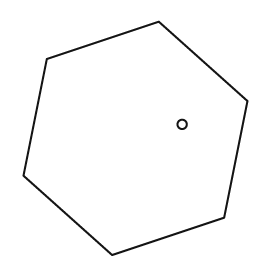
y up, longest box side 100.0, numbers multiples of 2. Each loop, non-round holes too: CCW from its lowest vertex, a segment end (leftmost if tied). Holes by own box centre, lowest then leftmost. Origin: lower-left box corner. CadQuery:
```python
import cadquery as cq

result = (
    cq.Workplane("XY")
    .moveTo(38.0, 0.0)
    .lineTo(86.0, 16.0)
    .lineTo(96.0, 66.0)
    .lineTo(58.0, 100.0)
    .lineTo(10.0, 84.0)
    .lineTo(0.0, 34.0)
    .close()
    .moveTo(68.0, 56.0)
    .circle(2.0)
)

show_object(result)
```